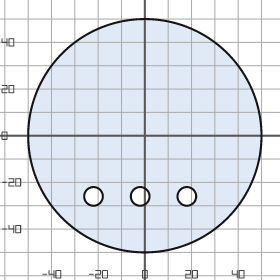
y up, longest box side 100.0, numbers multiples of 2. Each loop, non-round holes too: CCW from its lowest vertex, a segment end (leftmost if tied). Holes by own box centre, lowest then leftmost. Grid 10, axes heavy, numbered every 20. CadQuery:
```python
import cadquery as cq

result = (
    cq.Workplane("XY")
    .moveTo(0.0, 0.0)
    .circle(50.0)
    .moveTo(-22.0, -26.0)
    .circle(4.0)
    .moveTo(-2.0, -26.0)
    .circle(4.0)
    .moveTo(18.0, -26.0)
    .circle(4.0)
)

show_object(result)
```